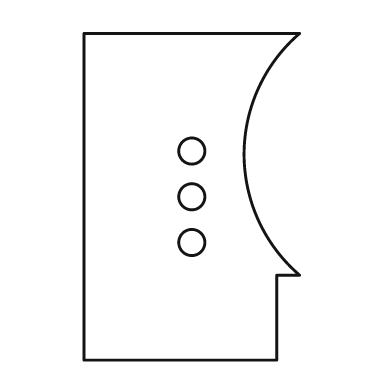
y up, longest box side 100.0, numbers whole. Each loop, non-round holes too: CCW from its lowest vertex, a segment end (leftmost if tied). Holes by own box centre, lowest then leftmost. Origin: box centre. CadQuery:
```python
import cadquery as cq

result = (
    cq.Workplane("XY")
    .moveTo(-33.0, -50.0)
    .lineTo(26.0, -50.0)
    .lineTo(26.0, -24.0)
    .lineTo(33.0, -24.0)
    .threePointArc((16.0, 13.0), (33.0, 50.0))
    .lineTo(-33.0, 50.0)
    .close()
    .moveTo(0.0, -14.0)
    .circle(4.0)
    .moveTo(0.0, 0.0)
    .circle(4.0)
    .moveTo(0.0, 14.0)
    .circle(4.0)
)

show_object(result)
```